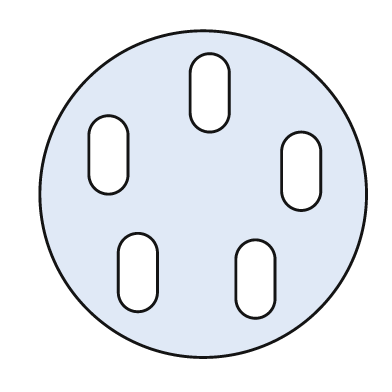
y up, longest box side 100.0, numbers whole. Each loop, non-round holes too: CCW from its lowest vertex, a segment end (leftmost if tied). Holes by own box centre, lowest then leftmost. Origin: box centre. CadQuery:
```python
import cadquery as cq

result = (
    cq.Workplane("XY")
    .moveTo(0.0, 0.0)
    .circle(50.0)
    .moveTo(10.0, -32.0)
    .threePointArc((16.0, -38.0), (22.0, -32.0))
    .lineTo(22.0, -20.0)
    .threePointArc((16.0, -14.0), (10.0, -20.0))
    .close()
    .moveTo(-26.0, -30.0)
    .threePointArc((-20.0, -36.0), (-14.0, -30.0))
    .lineTo(-14.0, -18.0)
    .threePointArc((-20.0, -12.0), (-26.0, -18.0))
    .close()
    .moveTo(24.0, 1.0)
    .threePointArc((30.0, -5.0), (36.0, 1.0))
    .lineTo(36.0, 13.0)
    .threePointArc((30.0, 19.0), (24.0, 13.0))
    .close()
    .moveTo(-35.0, 6.0)
    .threePointArc((-29.0, 0.0), (-23.0, 6.0))
    .lineTo(-23.0, 18.0)
    .threePointArc((-29.0, 24.0), (-35.0, 18.0))
    .close()
    .moveTo(-4.0, 25.0)
    .threePointArc((2.0, 19.0), (8.0, 25.0))
    .lineTo(8.0, 37.0)
    .threePointArc((2.0, 43.0), (-4.0, 37.0))
    .close()
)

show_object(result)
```